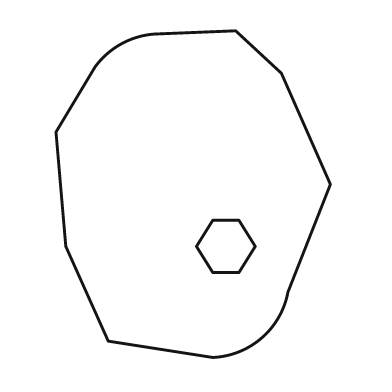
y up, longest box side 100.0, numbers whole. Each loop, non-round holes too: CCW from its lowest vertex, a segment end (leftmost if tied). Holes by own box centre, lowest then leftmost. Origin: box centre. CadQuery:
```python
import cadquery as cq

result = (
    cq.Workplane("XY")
    .moveTo(6.0, -50.0)
    .threePointArc((21.0, -44.0), (29.0, -30.0))
    .lineTo(42.0, 3.0)
    .lineTo(27.0, 37.0)
    .lineTo(13.0, 50.0)
    .lineTo(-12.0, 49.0)
    .threePointArc((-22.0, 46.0), (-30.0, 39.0))
    .lineTo(-42.0, 19.0)
    .lineTo(-39.0, -16.0)
    .lineTo(-26.0, -45.0)
    .close()
    .moveTo(6.0, -24.0)
    .lineTo(14.0, -24.0)
    .lineTo(19.0, -16.0)
    .lineTo(14.0, -8.0)
    .lineTo(6.0, -8.0)
    .lineTo(1.0, -16.0)
    .close()
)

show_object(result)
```